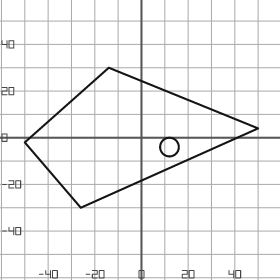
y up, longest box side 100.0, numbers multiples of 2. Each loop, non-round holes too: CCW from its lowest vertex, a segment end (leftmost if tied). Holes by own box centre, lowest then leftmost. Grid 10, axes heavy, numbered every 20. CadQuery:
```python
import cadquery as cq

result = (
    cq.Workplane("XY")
    .moveTo(-26.0, -30.0)
    .lineTo(50.0, 4.0)
    .lineTo(-14.0, 30.0)
    .lineTo(-50.0, -2.0)
    .close()
    .moveTo(12.0, -4.0)
    .circle(4.0)
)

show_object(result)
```